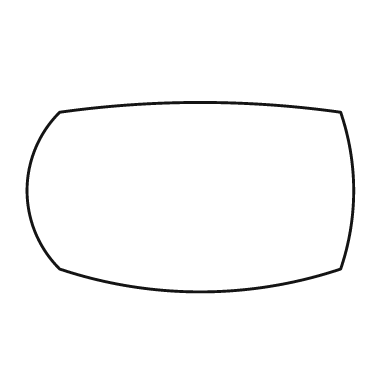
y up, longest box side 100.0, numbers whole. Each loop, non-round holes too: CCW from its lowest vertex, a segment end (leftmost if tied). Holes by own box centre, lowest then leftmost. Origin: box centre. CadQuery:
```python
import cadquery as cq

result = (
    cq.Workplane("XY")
    .moveTo(-40.0, -22.0)
    .threePointArc((3.0, -29.0), (46.0, -22.0))
    .threePointArc((50.0, 2.0), (46.0, 26.0))
    .threePointArc((3.0, 29.0), (-40.0, 26.0))
    .threePointArc((-50.0, 2.0), (-40.0, -22.0))
    .close()
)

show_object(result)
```